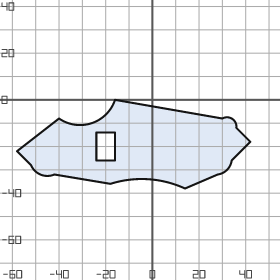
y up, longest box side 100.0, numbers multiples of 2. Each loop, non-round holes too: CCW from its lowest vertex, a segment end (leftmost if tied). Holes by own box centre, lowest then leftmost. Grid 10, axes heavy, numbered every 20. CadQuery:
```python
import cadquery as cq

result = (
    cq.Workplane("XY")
    .moveTo(14.0, -38.0)
    .lineTo(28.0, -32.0)
    .threePointArc((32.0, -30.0), (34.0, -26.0))
    .lineTo(42.0, -18.0)
    .lineTo(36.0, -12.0)
    .threePointArc((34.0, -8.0), (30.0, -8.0))
    .lineTo(-16.0, 0.0)
    .threePointArc((-26.0, -10.0), (-40.0, -8.0))
    .lineTo(-58.0, -22.0)
    .lineTo(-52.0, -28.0)
    .threePointArc((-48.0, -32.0), (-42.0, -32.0))
    .lineTo(-18.0, -36.0)
    .threePointArc((-2.0, -34.0), (14.0, -38.0))
    .close()
    .moveTo(-24.0, -26.0)
    .lineTo(-16.0, -26.0)
    .lineTo(-16.0, -14.0)
    .lineTo(-24.0, -14.0)
    .close()
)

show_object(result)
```